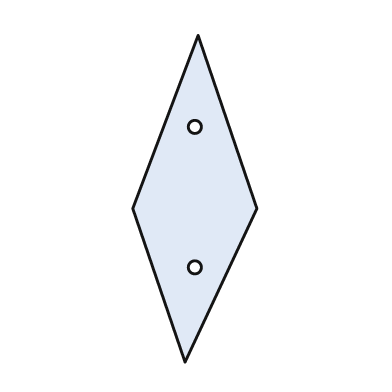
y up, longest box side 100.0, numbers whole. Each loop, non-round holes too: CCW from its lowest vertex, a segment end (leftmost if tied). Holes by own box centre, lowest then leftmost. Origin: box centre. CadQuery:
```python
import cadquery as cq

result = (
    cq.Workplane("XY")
    .moveTo(-3.0, -50.0)
    .lineTo(19.0, -3.0)
    .lineTo(1.0, 50.0)
    .lineTo(-19.0, -3.0)
    .close()
    .moveTo(0.0, -21.0)
    .circle(2.0)
    .moveTo(0.0, 22.0)
    .circle(2.0)
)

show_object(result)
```